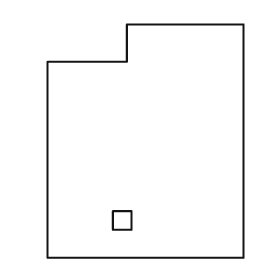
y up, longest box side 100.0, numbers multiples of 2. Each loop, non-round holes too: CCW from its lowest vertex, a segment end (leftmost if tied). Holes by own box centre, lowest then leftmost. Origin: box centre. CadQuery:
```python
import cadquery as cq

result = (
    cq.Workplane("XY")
    .moveTo(-42.0, -50.0)
    .lineTo(42.0, -50.0)
    .lineTo(42.0, 50.0)
    .lineTo(-8.0, 50.0)
    .lineTo(-8.0, 34.0)
    .lineTo(-42.0, 34.0)
    .close()
    .moveTo(-14.0, -38.0)
    .lineTo(-6.0, -38.0)
    .lineTo(-6.0, -30.0)
    .lineTo(-14.0, -30.0)
    .close()
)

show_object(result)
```